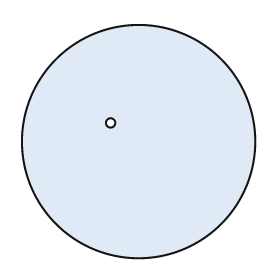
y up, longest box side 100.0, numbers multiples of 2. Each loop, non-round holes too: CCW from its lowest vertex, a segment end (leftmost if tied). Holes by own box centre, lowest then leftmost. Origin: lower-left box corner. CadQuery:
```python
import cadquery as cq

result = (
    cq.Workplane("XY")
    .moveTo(50.0, 50.0)
    .circle(50.0)
    .moveTo(38.0, 58.0)
    .circle(2.0)
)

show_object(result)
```